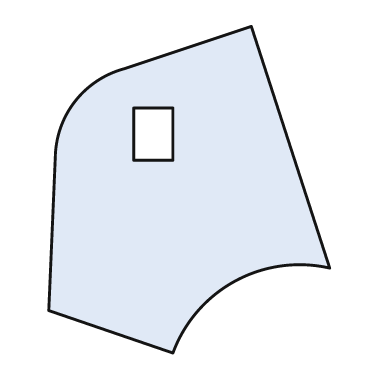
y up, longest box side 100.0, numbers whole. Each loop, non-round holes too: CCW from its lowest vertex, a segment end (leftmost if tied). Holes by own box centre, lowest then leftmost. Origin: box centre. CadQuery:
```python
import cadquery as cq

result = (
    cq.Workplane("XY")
    .moveTo(-5.0, -50.0)
    .threePointArc((14.0, -28.0), (43.0, -24.0))
    .lineTo(19.0, 50.0)
    .lineTo(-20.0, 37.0)
    .threePointArc((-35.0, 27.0), (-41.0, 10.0))
    .lineTo(-43.0, -37.0)
    .close()
    .moveTo(-17.0, 9.0)
    .lineTo(-5.0, 9.0)
    .lineTo(-5.0, 25.0)
    .lineTo(-17.0, 25.0)
    .close()
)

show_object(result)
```